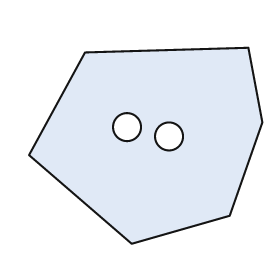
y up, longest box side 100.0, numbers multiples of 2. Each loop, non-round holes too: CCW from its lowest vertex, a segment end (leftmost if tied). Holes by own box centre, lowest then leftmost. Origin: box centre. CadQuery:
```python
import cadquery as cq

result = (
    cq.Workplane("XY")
    .moveTo(-6.0, -42.0)
    .lineTo(36.0, -30.0)
    .lineTo(50.0, 10.0)
    .lineTo(44.0, 42.0)
    .lineTo(-26.0, 40.0)
    .lineTo(-50.0, -4.0)
    .close()
    .moveTo(10.0, 4.0)
    .circle(6.0)
    .moveTo(-8.0, 8.0)
    .circle(6.0)
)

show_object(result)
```